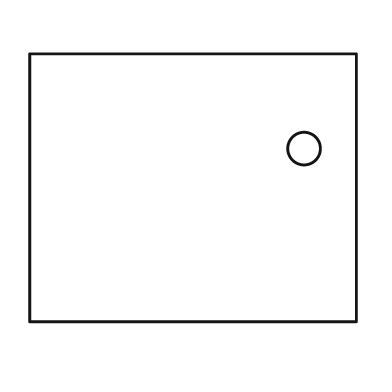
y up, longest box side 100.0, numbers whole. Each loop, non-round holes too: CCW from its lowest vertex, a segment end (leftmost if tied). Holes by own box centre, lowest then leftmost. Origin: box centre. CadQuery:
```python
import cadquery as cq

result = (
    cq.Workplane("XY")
    .moveTo(-50.0, -41.0)
    .lineTo(50.0, -41.0)
    .lineTo(50.0, 41.0)
    .lineTo(-50.0, 41.0)
    .close()
    .moveTo(34.0, 12.0)
    .circle(5.0)
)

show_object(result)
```